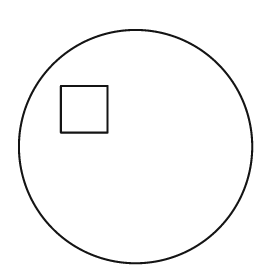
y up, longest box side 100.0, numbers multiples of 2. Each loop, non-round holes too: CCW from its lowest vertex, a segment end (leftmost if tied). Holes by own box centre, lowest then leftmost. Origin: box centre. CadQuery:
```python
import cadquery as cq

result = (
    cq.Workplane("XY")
    .moveTo(0.0, 0.0)
    .circle(50.0)
    .moveTo(-32.0, 6.0)
    .lineTo(-12.0, 6.0)
    .lineTo(-12.0, 26.0)
    .lineTo(-32.0, 26.0)
    .close()
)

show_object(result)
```